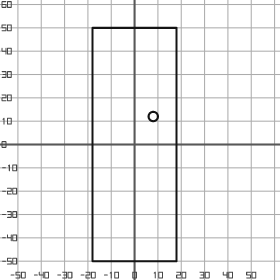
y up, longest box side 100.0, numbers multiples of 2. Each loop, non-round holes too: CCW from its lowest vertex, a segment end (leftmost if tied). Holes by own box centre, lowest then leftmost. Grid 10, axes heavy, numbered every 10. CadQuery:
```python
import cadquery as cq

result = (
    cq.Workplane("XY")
    .moveTo(-18.0, -50.0)
    .lineTo(18.0, -50.0)
    .lineTo(18.0, 50.0)
    .lineTo(-18.0, 50.0)
    .close()
    .moveTo(8.0, 12.0)
    .circle(2.0)
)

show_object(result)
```